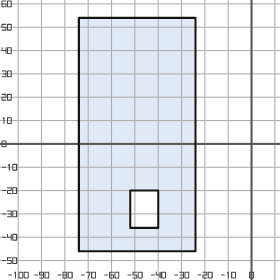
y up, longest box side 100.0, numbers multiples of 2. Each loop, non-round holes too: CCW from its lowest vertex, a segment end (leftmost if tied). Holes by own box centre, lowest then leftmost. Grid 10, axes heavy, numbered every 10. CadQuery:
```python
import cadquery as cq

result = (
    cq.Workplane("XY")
    .moveTo(-74.0, -46.0)
    .lineTo(-24.0, -46.0)
    .lineTo(-24.0, 54.0)
    .lineTo(-74.0, 54.0)
    .close()
    .moveTo(-52.0, -36.0)
    .lineTo(-40.0, -36.0)
    .lineTo(-40.0, -20.0)
    .lineTo(-52.0, -20.0)
    .close()
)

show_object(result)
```